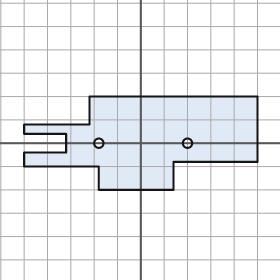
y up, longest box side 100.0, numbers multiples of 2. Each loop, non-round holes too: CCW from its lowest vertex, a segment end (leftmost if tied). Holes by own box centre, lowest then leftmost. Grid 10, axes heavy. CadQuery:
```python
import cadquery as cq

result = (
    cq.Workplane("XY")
    .moveTo(-18.0, -20.0)
    .lineTo(14.0, -20.0)
    .lineTo(14.0, -8.0)
    .lineTo(50.0, -8.0)
    .lineTo(50.0, 20.0)
    .lineTo(-22.0, 20.0)
    .lineTo(-22.0, 8.0)
    .lineTo(-50.0, 8.0)
    .lineTo(-50.0, 4.0)
    .lineTo(-32.0, 4.0)
    .lineTo(-32.0, -4.0)
    .lineTo(-50.0, -4.0)
    .lineTo(-50.0, -10.0)
    .lineTo(-18.0, -10.0)
    .close()
    .moveTo(-18.0, 0.0)
    .circle(2.0)
    .moveTo(20.0, 0.0)
    .circle(2.0)
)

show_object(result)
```